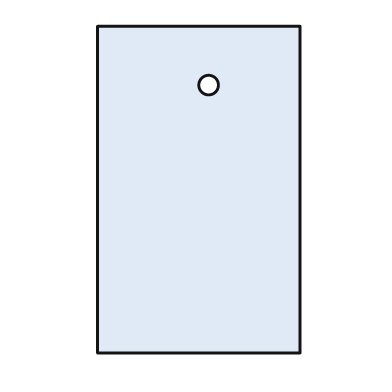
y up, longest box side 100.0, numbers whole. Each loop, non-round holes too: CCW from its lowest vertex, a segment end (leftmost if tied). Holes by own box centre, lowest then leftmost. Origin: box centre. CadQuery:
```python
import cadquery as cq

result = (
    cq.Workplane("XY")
    .moveTo(-31.0, -50.0)
    .lineTo(31.0, -50.0)
    .lineTo(31.0, 50.0)
    .lineTo(-31.0, 50.0)
    .close()
    .moveTo(3.0, 32.0)
    .circle(3.0)
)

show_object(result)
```